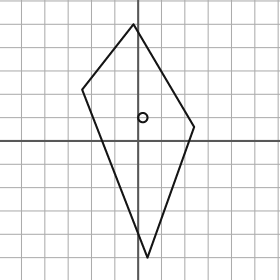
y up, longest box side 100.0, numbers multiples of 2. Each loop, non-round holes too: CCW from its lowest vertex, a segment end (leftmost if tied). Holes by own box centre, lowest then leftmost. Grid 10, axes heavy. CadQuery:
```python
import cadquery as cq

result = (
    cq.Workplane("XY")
    .moveTo(4.0, -50.0)
    .lineTo(24.0, 6.0)
    .lineTo(-2.0, 50.0)
    .lineTo(-24.0, 22.0)
    .close()
    .moveTo(2.0, 10.0)
    .circle(2.0)
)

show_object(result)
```